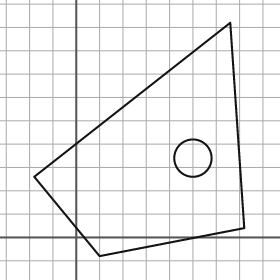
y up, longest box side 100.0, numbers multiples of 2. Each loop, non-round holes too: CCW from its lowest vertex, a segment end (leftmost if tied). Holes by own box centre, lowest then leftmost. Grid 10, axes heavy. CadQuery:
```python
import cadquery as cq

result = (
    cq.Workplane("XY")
    .moveTo(10.0, -8.0)
    .lineTo(72.0, 4.0)
    .lineTo(66.0, 92.0)
    .lineTo(-18.0, 26.0)
    .close()
    .moveTo(50.0, 34.0)
    .circle(8.0)
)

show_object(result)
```